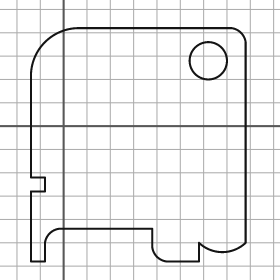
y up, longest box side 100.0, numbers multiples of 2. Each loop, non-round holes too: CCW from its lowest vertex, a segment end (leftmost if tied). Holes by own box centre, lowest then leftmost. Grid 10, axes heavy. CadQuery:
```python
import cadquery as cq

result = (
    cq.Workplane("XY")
    .moveTo(-14.0, -58.0)
    .lineTo(-8.0, -58.0)
    .lineTo(-8.0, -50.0)
    .threePointArc((-6.0, -46.0), (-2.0, -44.0))
    .lineTo(38.0, -44.0)
    .lineTo(38.0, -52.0)
    .threePointArc((40.0, -56.0), (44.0, -58.0))
    .lineTo(58.0, -58.0)
    .lineTo(58.0, -50.0)
    .threePointArc((68.0, -54.0), (78.0, -50.0))
    .lineTo(78.0, 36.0)
    .threePointArc((76.0, 40.0), (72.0, 42.0))
    .lineTo(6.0, 42.0)
    .threePointArc((-8.0, 36.0), (-14.0, 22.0))
    .lineTo(-14.0, -22.0)
    .lineTo(-8.0, -22.0)
    .lineTo(-8.0, -28.0)
    .lineTo(-14.0, -28.0)
    .close()
    .moveTo(62.0, 28.0)
    .circle(8.0)
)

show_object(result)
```